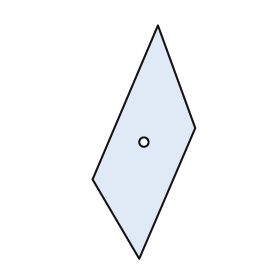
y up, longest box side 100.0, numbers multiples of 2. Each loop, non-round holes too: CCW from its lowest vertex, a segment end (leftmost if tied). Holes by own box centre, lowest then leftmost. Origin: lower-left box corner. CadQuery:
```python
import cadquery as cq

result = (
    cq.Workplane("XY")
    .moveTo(20.0, 0.0)
    .lineTo(44.0, 56.0)
    .lineTo(28.0, 100.0)
    .lineTo(0.0, 34.0)
    .close()
    .moveTo(22.0, 50.0)
    .circle(2.0)
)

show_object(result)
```